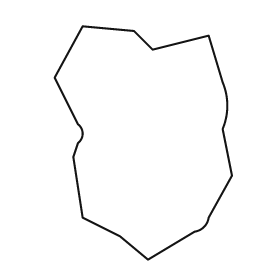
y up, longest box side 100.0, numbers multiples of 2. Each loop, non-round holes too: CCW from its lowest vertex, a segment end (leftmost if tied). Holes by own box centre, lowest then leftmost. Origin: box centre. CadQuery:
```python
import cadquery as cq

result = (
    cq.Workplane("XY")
    .moveTo(2.0, -50.0)
    .lineTo(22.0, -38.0)
    .threePointArc((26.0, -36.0), (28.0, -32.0))
    .lineTo(38.0, -14.0)
    .lineTo(34.0, 6.0)
    .threePointArc((36.0, 16.0), (34.0, 26.0))
    .lineTo(28.0, 46.0)
    .lineTo(4.0, 40.0)
    .lineTo(-4.0, 48.0)
    .lineTo(-26.0, 50.0)
    .lineTo(-38.0, 28.0)
    .lineTo(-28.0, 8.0)
    .threePointArc((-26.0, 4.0), (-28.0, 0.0))
    .lineTo(-30.0, -6.0)
    .lineTo(-26.0, -32.0)
    .lineTo(-10.0, -40.0)
    .close()
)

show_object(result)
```